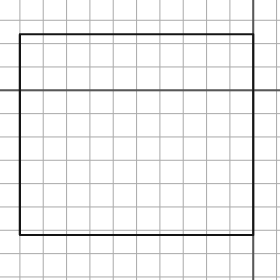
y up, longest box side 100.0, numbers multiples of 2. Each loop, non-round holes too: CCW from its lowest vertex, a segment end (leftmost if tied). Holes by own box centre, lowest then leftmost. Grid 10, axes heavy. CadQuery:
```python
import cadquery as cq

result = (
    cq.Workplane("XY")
    .moveTo(-100.0, -62.0)
    .lineTo(0.0, -62.0)
    .lineTo(0.0, 24.0)
    .lineTo(-100.0, 24.0)
    .close()
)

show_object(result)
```